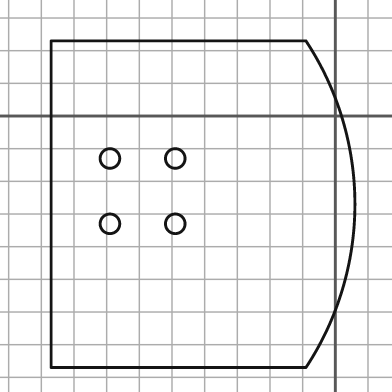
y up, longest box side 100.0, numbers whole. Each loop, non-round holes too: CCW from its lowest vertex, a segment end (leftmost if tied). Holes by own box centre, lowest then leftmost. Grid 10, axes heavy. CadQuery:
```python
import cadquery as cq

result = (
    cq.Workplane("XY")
    .moveTo(-87.0, -77.0)
    .lineTo(-9.0, -77.0)
    .threePointArc((6.0, -27.0), (-9.0, 23.0))
    .lineTo(-87.0, 23.0)
    .close()
    .moveTo(-69.0, -33.0)
    .circle(3.0)
    .moveTo(-49.0, -33.0)
    .circle(3.0)
    .moveTo(-69.0, -13.0)
    .circle(3.0)
    .moveTo(-49.0, -13.0)
    .circle(3.0)
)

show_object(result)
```